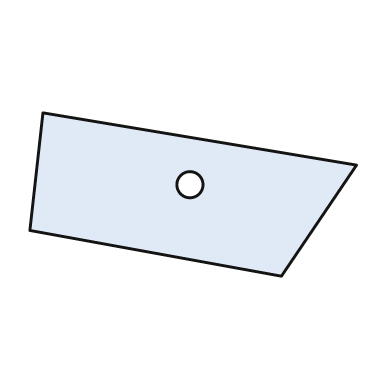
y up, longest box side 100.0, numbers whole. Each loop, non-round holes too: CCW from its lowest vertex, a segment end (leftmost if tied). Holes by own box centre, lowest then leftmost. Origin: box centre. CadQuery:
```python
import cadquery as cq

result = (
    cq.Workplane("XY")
    .moveTo(27.0, -25.0)
    .lineTo(50.0, 9.0)
    .lineTo(-46.0, 25.0)
    .lineTo(-50.0, -11.0)
    .close()
    .moveTo(-1.0, 3.0)
    .circle(4.0)
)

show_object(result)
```